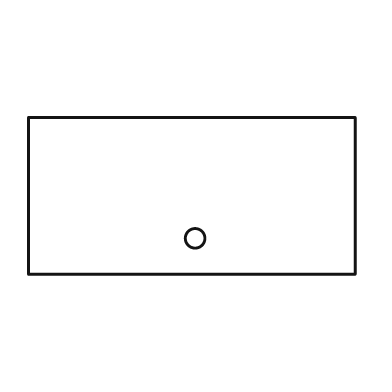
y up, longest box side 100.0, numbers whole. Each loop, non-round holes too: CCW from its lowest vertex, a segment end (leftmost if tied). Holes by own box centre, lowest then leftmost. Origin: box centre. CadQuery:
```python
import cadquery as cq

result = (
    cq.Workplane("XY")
    .moveTo(-50.0, -24.0)
    .lineTo(50.0, -24.0)
    .lineTo(50.0, 24.0)
    .lineTo(-50.0, 24.0)
    .close()
    .moveTo(1.0, -13.0)
    .circle(3.0)
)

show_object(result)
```